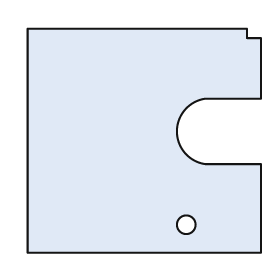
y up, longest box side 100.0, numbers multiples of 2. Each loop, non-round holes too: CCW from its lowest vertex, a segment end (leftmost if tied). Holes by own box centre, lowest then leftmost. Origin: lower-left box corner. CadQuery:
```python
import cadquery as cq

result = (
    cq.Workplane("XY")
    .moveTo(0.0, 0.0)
    .lineTo(100.0, 0.0)
    .lineTo(100.0, 38.0)
    .lineTo(76.0, 38.0)
    .threePointArc((64.0, 52.0), (76.0, 66.0))
    .lineTo(100.0, 66.0)
    .lineTo(100.0, 92.0)
    .lineTo(94.0, 92.0)
    .lineTo(94.0, 96.0)
    .lineTo(0.0, 96.0)
    .close()
    .moveTo(68.0, 12.0)
    .circle(4.0)
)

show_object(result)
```